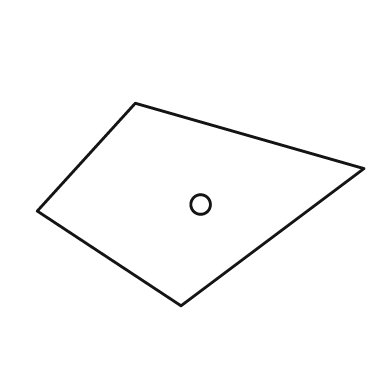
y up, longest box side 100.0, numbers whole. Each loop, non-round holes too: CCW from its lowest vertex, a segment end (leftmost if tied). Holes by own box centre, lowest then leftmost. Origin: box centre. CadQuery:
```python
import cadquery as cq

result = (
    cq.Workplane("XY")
    .moveTo(-6.0, -31.0)
    .lineTo(50.0, 11.0)
    .lineTo(-20.0, 31.0)
    .lineTo(-50.0, -2.0)
    .close()
    .moveTo(0.0, 0.0)
    .circle(3.0)
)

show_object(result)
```